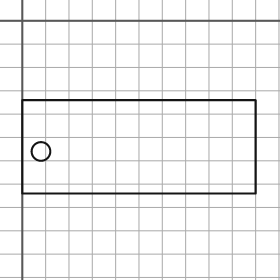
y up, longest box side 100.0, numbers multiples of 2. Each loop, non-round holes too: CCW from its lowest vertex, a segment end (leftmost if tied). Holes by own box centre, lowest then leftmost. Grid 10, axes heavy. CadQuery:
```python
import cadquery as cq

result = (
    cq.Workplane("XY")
    .moveTo(0.0, -74.0)
    .lineTo(100.0, -74.0)
    .lineTo(100.0, -34.0)
    .lineTo(0.0, -34.0)
    .close()
    .moveTo(8.0, -56.0)
    .circle(4.0)
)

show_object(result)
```